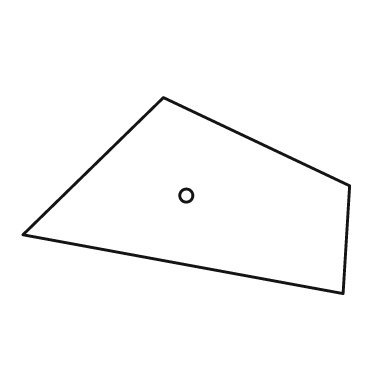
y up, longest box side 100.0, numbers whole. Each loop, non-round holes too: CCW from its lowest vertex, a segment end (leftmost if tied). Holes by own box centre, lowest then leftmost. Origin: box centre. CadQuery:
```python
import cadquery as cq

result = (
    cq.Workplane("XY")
    .moveTo(48.0, -30.0)
    .lineTo(50.0, 3.0)
    .lineTo(-7.0, 30.0)
    .lineTo(-50.0, -12.0)
    .close()
    .moveTo(0.0, 0.0)
    .circle(2.0)
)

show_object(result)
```